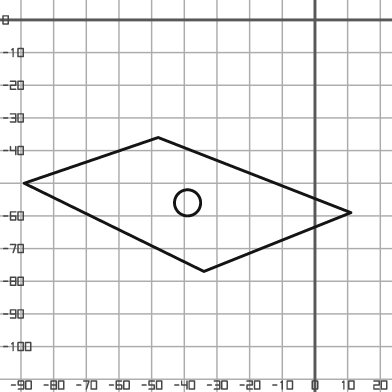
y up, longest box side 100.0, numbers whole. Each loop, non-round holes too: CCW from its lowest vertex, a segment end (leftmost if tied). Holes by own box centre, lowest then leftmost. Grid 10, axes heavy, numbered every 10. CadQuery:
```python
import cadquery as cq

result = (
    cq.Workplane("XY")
    .moveTo(-34.0, -77.0)
    .lineTo(11.0, -59.0)
    .lineTo(-48.0, -36.0)
    .lineTo(-89.0, -50.0)
    .close()
    .moveTo(-39.0, -56.0)
    .circle(4.0)
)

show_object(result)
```